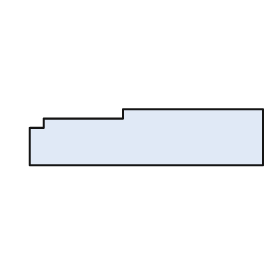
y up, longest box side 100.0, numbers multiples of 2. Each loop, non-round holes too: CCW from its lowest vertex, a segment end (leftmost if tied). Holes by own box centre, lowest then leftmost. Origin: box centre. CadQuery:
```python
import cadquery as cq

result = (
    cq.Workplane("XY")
    .moveTo(-50.0, -12.0)
    .lineTo(50.0, -12.0)
    .lineTo(50.0, 12.0)
    .lineTo(-10.0, 12.0)
    .lineTo(-10.0, 8.0)
    .lineTo(-44.0, 8.0)
    .lineTo(-44.0, 4.0)
    .lineTo(-50.0, 4.0)
    .close()
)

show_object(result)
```